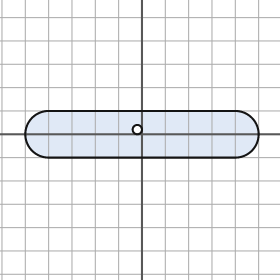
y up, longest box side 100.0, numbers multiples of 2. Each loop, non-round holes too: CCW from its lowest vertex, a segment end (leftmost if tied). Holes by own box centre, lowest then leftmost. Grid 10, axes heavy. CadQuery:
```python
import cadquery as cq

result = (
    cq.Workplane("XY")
    .moveTo(-40.0, -10.0)
    .lineTo(40.0, -10.0)
    .threePointArc((50.0, 0.0), (40.0, 10.0))
    .lineTo(-40.0, 10.0)
    .threePointArc((-50.0, 0.0), (-40.0, -10.0))
    .close()
    .moveTo(-2.0, 2.0)
    .circle(2.0)
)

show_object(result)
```